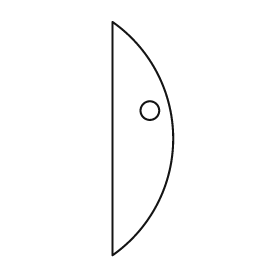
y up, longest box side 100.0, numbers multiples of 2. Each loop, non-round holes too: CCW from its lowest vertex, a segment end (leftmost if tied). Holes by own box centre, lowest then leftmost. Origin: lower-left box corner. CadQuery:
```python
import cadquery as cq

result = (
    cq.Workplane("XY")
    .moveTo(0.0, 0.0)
    .threePointArc((26.0, 50.0), (0.0, 100.0))
    .close()
    .moveTo(16.0, 62.0)
    .circle(4.0)
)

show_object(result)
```